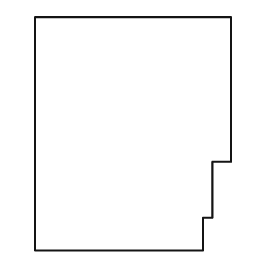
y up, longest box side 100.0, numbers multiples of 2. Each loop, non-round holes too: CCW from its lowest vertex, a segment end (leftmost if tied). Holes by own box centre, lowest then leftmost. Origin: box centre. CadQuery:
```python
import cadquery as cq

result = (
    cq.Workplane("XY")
    .moveTo(-42.0, -50.0)
    .lineTo(30.0, -50.0)
    .lineTo(30.0, -36.0)
    .lineTo(34.0, -36.0)
    .lineTo(34.0, -12.0)
    .lineTo(42.0, -12.0)
    .lineTo(42.0, 50.0)
    .lineTo(-42.0, 50.0)
    .close()
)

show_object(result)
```